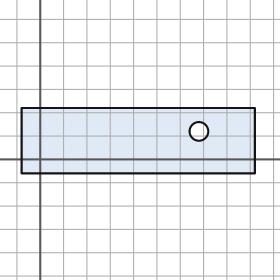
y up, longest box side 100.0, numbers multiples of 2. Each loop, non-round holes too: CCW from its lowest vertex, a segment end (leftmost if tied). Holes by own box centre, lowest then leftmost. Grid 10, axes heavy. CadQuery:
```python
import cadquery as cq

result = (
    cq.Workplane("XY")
    .moveTo(-8.0, -6.0)
    .lineTo(92.0, -6.0)
    .lineTo(92.0, 22.0)
    .lineTo(-8.0, 22.0)
    .close()
    .moveTo(68.0, 12.0)
    .circle(4.0)
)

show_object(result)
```